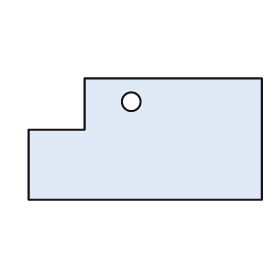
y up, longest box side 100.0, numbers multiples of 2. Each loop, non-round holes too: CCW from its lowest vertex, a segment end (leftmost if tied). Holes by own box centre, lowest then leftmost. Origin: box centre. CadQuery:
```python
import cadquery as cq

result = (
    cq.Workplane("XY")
    .moveTo(-50.0, -26.0)
    .lineTo(50.0, -26.0)
    .lineTo(50.0, 26.0)
    .lineTo(-26.0, 26.0)
    .lineTo(-26.0, 4.0)
    .lineTo(-50.0, 4.0)
    .close()
    .moveTo(-6.0, 16.0)
    .circle(4.0)
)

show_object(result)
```